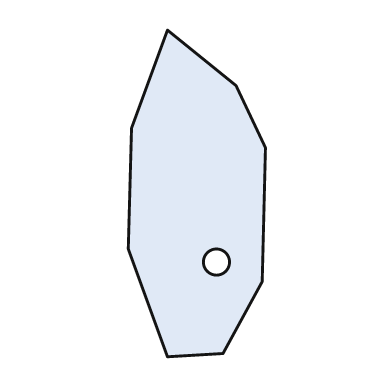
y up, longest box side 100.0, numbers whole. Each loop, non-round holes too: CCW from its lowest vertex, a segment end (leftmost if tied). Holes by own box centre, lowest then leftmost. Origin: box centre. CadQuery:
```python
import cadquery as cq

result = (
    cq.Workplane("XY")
    .moveTo(-9.0, -50.0)
    .lineTo(8.0, -49.0)
    .lineTo(20.0, -27.0)
    .lineTo(21.0, 14.0)
    .lineTo(12.0, 33.0)
    .lineTo(-9.0, 50.0)
    .lineTo(-20.0, 20.0)
    .lineTo(-21.0, -17.0)
    .close()
    .moveTo(6.0, -21.0)
    .circle(4.0)
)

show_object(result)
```